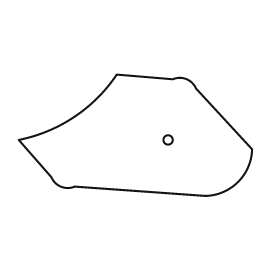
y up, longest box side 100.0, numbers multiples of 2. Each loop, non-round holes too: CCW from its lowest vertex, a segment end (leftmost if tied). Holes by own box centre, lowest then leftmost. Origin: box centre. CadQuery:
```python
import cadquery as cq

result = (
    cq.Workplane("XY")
    .moveTo(30.0, -26.0)
    .threePointArc((44.0, -20.0), (50.0, -6.0))
    .lineTo(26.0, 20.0)
    .threePointArc((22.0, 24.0), (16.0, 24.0))
    .lineTo(-8.0, 26.0)
    .threePointArc((-26.0, 8.0), (-50.0, -2.0))
    .lineTo(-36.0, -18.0)
    .threePointArc((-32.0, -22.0), (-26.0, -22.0))
    .close()
    .moveTo(14.0, -2.0)
    .circle(2.0)
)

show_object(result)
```